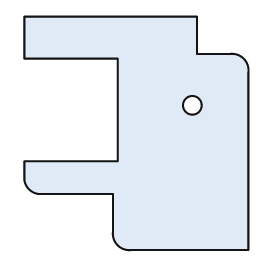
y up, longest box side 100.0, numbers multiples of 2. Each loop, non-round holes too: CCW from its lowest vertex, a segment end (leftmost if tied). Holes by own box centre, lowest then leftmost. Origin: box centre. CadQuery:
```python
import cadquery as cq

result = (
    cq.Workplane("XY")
    .moveTo(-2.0, -50.0)
    .lineTo(48.0, -50.0)
    .lineTo(48.0, 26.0)
    .threePointArc((46.0, 32.0), (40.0, 34.0))
    .lineTo(26.0, 34.0)
    .lineTo(26.0, 50.0)
    .lineTo(-48.0, 50.0)
    .lineTo(-48.0, 32.0)
    .lineTo(-8.0, 32.0)
    .lineTo(-8.0, -12.0)
    .lineTo(-48.0, -12.0)
    .lineTo(-48.0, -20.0)
    .threePointArc((-46.0, -24.0), (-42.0, -26.0))
    .lineTo(-10.0, -26.0)
    .lineTo(-10.0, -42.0)
    .threePointArc((-8.0, -48.0), (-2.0, -50.0))
    .close()
    .moveTo(24.0, 12.0)
    .circle(4.0)
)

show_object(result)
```